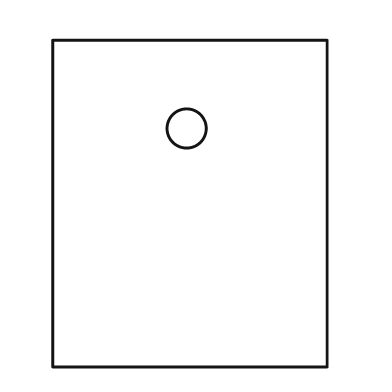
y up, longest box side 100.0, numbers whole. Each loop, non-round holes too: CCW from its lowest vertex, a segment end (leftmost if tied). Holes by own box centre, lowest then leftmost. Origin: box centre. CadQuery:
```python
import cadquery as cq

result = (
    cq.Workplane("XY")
    .moveTo(-42.0, -50.0)
    .lineTo(42.0, -50.0)
    .lineTo(42.0, 50.0)
    .lineTo(-42.0, 50.0)
    .close()
    .moveTo(-1.0, 23.0)
    .circle(6.0)
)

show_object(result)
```